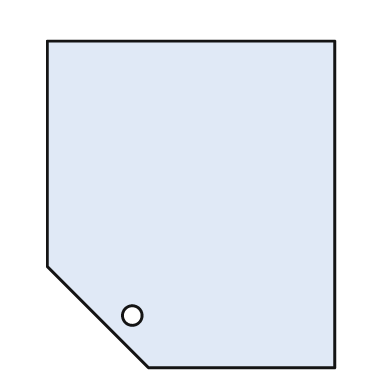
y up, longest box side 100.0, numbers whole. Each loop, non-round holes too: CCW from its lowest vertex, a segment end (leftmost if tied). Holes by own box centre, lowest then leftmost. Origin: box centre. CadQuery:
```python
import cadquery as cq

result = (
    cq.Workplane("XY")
    .moveTo(-13.0, -50.0)
    .lineTo(44.0, -50.0)
    .lineTo(44.0, 50.0)
    .lineTo(-44.0, 50.0)
    .lineTo(-44.0, -19.0)
    .close()
    .moveTo(-18.0, -34.0)
    .circle(3.0)
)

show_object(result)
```